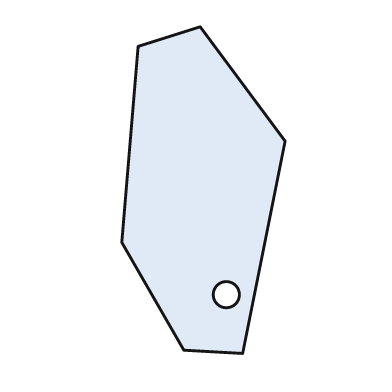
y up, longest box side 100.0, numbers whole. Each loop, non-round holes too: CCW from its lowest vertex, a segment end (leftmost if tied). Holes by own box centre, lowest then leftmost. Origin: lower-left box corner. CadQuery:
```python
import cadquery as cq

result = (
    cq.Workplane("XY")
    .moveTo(37.0, 0.0)
    .lineTo(50.0, 65.0)
    .lineTo(24.0, 100.0)
    .lineTo(5.0, 94.0)
    .lineTo(0.0, 34.0)
    .lineTo(19.0, 1.0)
    .close()
    .moveTo(32.0, 18.0)
    .circle(4.0)
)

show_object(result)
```